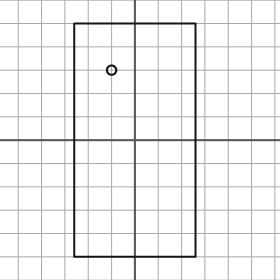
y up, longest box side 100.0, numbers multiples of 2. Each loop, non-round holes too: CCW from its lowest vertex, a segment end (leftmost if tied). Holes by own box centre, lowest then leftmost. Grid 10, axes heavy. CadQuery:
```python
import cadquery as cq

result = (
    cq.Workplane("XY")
    .moveTo(-26.0, -50.0)
    .lineTo(26.0, -50.0)
    .lineTo(26.0, 50.0)
    .lineTo(-26.0, 50.0)
    .close()
    .moveTo(-10.0, 30.0)
    .circle(2.0)
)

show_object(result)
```